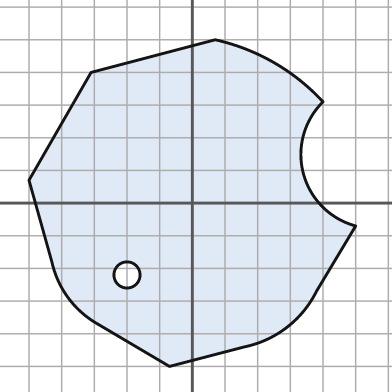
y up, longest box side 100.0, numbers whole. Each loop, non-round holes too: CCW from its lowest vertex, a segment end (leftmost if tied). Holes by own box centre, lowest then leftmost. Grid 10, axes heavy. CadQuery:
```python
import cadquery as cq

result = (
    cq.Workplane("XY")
    .moveTo(-7.0, -50.0)
    .lineTo(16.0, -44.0)
    .threePointArc((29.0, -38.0), (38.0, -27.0))
    .lineTo(50.0, -7.0)
    .threePointArc((34.0, 9.0), (40.0, 31.0))
    .threePointArc((25.0, 43.0), (7.0, 50.0))
    .lineTo(-31.0, 40.0)
    .lineTo(-50.0, 7.0)
    .lineTo(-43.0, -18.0)
    .threePointArc((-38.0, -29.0), (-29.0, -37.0))
    .close()
    .moveTo(-20.0, -22.0)
    .circle(4.0)
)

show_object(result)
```